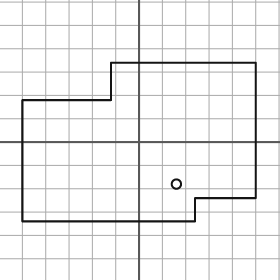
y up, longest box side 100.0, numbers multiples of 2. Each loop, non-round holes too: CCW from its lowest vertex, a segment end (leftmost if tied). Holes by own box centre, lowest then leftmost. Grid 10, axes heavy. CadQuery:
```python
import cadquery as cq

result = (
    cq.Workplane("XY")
    .moveTo(-50.0, -34.0)
    .lineTo(24.0, -34.0)
    .lineTo(24.0, -24.0)
    .lineTo(50.0, -24.0)
    .lineTo(50.0, 34.0)
    .lineTo(-12.0, 34.0)
    .lineTo(-12.0, 18.0)
    .lineTo(-50.0, 18.0)
    .close()
    .moveTo(16.0, -18.0)
    .circle(2.0)
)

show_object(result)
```